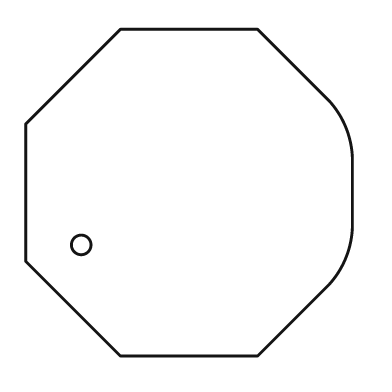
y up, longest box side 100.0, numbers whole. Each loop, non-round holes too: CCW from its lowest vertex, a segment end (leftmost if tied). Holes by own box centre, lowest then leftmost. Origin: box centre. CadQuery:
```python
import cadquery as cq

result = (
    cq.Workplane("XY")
    .moveTo(-21.0, -50.0)
    .lineTo(21.0, -50.0)
    .lineTo(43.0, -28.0)
    .threePointArc((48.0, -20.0), (50.0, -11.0))
    .lineTo(50.0, 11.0)
    .threePointArc((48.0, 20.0), (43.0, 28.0))
    .lineTo(21.0, 50.0)
    .lineTo(-21.0, 50.0)
    .lineTo(-50.0, 21.0)
    .lineTo(-50.0, -21.0)
    .close()
    .moveTo(-33.0, -16.0)
    .circle(3.0)
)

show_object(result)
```